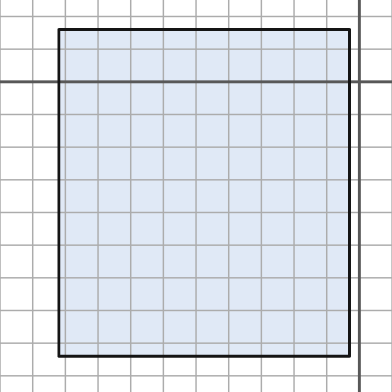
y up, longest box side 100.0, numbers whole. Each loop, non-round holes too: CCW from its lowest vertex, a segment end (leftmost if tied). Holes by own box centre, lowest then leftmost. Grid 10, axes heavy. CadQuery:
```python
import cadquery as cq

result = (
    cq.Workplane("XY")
    .moveTo(-92.0, -84.0)
    .lineTo(-3.0, -84.0)
    .lineTo(-3.0, 16.0)
    .lineTo(-92.0, 16.0)
    .close()
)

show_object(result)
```